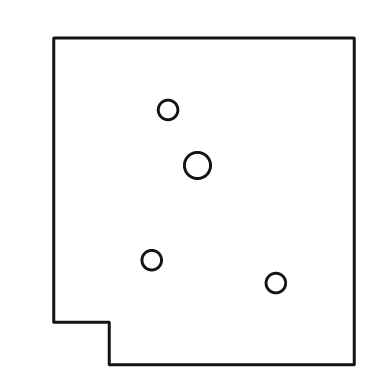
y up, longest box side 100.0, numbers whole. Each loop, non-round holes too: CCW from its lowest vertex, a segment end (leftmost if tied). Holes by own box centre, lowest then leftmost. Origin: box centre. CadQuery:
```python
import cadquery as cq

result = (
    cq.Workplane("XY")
    .moveTo(-29.0, -50.0)
    .lineTo(46.0, -50.0)
    .lineTo(46.0, 50.0)
    .lineTo(-46.0, 50.0)
    .lineTo(-46.0, -37.0)
    .lineTo(-29.0, -37.0)
    .close()
    .moveTo(22.0, -25.0)
    .circle(3.0)
    .moveTo(-16.0, -18.0)
    .circle(3.0)
    .moveTo(-2.0, 11.0)
    .circle(4.0)
    .moveTo(-11.0, 28.0)
    .circle(3.0)
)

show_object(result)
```